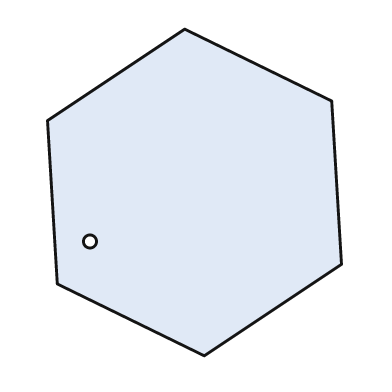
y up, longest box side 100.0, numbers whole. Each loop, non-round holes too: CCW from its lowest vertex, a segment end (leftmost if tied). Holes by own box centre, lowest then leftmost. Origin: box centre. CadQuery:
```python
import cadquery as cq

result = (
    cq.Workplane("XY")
    .moveTo(3.0, -50.0)
    .lineTo(45.0, -22.0)
    .lineTo(42.0, 28.0)
    .lineTo(-3.0, 50.0)
    .lineTo(-45.0, 22.0)
    .lineTo(-42.0, -28.0)
    .close()
    .moveTo(-32.0, -15.0)
    .circle(2.0)
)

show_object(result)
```